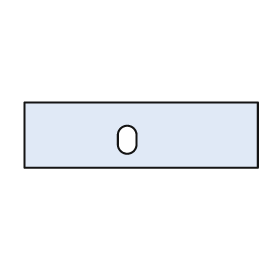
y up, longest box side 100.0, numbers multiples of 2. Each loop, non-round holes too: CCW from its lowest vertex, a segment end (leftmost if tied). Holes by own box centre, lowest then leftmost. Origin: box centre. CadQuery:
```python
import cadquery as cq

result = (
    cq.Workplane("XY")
    .moveTo(-50.0, -14.0)
    .lineTo(50.0, -14.0)
    .lineTo(50.0, 14.0)
    .lineTo(-50.0, 14.0)
    .close()
    .moveTo(-10.0, -4.0)
    .threePointArc((-6.0, -8.0), (-2.0, -4.0))
    .lineTo(-2.0, 0.0)
    .threePointArc((-6.0, 4.0), (-10.0, 0.0))
    .close()
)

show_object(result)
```